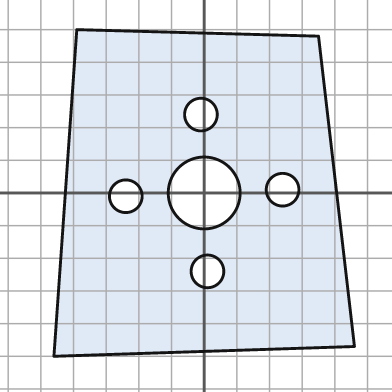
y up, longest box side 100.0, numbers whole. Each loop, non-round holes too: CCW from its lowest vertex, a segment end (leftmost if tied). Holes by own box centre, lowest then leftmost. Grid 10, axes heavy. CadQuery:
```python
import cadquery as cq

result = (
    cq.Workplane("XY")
    .moveTo(-46.0, -50.0)
    .lineTo(46.0, -47.0)
    .lineTo(35.0, 48.0)
    .lineTo(-39.0, 50.0)
    .close()
    .moveTo(1.0, -24.0)
    .circle(5.0)
    .moveTo(-24.0, -1.0)
    .circle(5.0)
    .moveTo(0.0, 0.0)
    .circle(11.0)
    .moveTo(24.0, 1.0)
    .circle(5.0)
    .moveTo(-1.0, 24.0)
    .circle(5.0)
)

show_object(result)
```